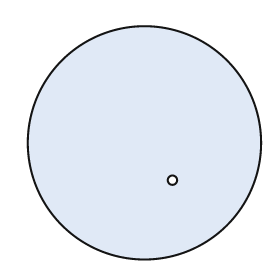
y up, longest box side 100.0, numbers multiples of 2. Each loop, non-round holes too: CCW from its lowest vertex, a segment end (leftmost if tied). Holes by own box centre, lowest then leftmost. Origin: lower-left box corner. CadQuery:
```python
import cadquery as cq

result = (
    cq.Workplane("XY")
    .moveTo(50.0, 50.0)
    .circle(50.0)
    .moveTo(62.0, 34.0)
    .circle(2.0)
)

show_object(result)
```